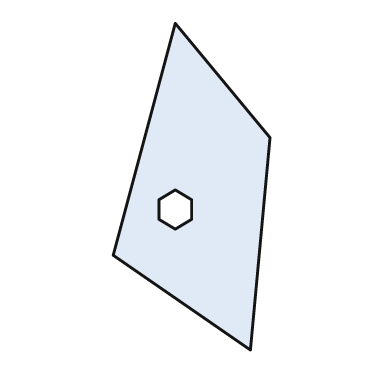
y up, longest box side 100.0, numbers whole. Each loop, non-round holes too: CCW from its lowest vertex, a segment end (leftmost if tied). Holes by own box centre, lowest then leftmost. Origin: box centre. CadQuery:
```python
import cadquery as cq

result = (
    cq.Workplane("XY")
    .moveTo(18.0, -50.0)
    .lineTo(24.0, 15.0)
    .lineTo(-5.0, 50.0)
    .lineTo(-24.0, -21.0)
    .close()
    .moveTo(-5.0, -13.0)
    .lineTo(0.0, -10.0)
    .lineTo(0.0, -4.0)
    .lineTo(-5.0, -1.0)
    .lineTo(-10.0, -4.0)
    .lineTo(-10.0, -10.0)
    .close()
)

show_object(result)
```